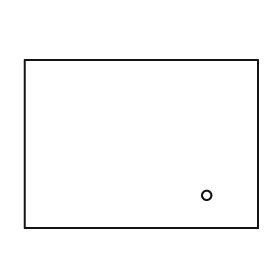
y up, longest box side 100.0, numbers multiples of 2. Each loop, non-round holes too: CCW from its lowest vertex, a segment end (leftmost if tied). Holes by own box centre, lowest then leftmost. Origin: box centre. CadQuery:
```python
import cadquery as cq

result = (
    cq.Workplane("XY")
    .moveTo(-50.0, -36.0)
    .lineTo(50.0, -36.0)
    .lineTo(50.0, 36.0)
    .lineTo(-50.0, 36.0)
    .close()
    .moveTo(28.0, -22.0)
    .circle(2.0)
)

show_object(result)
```